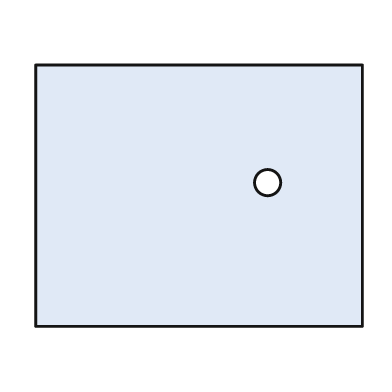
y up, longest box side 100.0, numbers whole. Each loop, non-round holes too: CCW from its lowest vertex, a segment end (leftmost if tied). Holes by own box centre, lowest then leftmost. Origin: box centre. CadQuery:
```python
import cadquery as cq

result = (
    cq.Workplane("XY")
    .moveTo(-50.0, -40.0)
    .lineTo(50.0, -40.0)
    .lineTo(50.0, 40.0)
    .lineTo(-50.0, 40.0)
    .close()
    .moveTo(21.0, 4.0)
    .circle(4.0)
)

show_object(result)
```